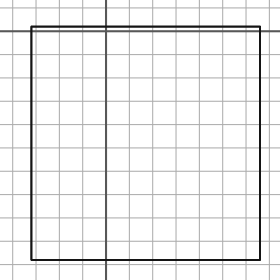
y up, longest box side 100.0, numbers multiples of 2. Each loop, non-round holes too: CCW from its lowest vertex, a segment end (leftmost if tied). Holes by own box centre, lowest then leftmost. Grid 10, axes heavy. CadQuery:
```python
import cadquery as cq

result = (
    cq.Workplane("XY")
    .moveTo(-32.0, -98.0)
    .lineTo(66.0, -98.0)
    .lineTo(66.0, 2.0)
    .lineTo(-32.0, 2.0)
    .close()
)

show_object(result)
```